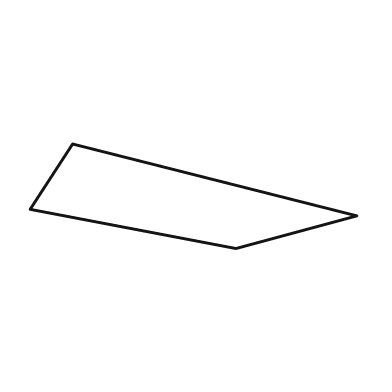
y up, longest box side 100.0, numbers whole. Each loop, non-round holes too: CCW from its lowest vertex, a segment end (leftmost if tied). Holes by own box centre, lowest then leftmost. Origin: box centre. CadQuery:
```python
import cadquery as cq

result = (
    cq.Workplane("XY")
    .moveTo(13.0, -16.0)
    .lineTo(50.0, -6.0)
    .lineTo(-37.0, 16.0)
    .lineTo(-50.0, -4.0)
    .close()
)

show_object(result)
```